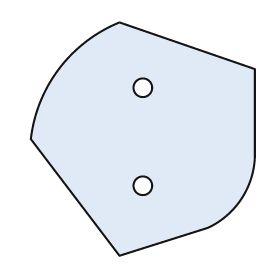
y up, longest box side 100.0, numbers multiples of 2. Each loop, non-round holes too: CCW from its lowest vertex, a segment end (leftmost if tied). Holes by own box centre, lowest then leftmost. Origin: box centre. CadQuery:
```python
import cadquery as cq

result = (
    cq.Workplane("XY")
    .moveTo(-10.0, -50.0)
    .lineTo(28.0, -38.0)
    .threePointArc((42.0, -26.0), (48.0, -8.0))
    .lineTo(48.0, 30.0)
    .lineTo(-10.0, 50.0)
    .threePointArc((-36.0, 30.0), (-48.0, 0.0))
    .close()
    .moveTo(0.0, -20.0)
    .circle(4.0)
    .moveTo(0.0, 22.0)
    .circle(4.0)
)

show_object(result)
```